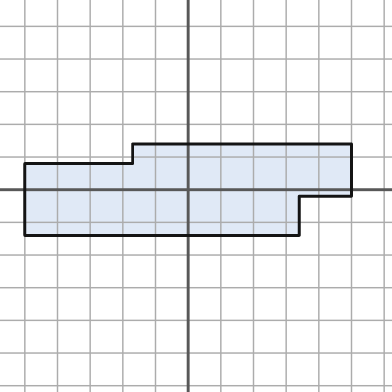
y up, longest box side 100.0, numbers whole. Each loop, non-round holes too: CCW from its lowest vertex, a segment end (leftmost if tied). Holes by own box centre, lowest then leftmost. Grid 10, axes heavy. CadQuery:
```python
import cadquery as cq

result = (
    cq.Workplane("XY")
    .moveTo(-50.0, -14.0)
    .lineTo(34.0, -14.0)
    .lineTo(34.0, -2.0)
    .lineTo(50.0, -2.0)
    .lineTo(50.0, 14.0)
    .lineTo(-17.0, 14.0)
    .lineTo(-17.0, 8.0)
    .lineTo(-50.0, 8.0)
    .close()
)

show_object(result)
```